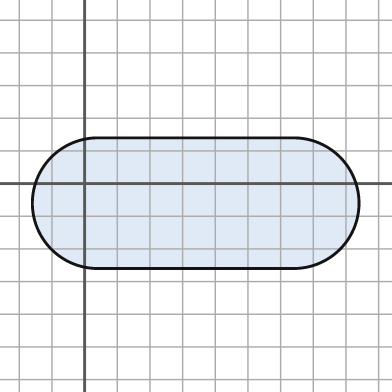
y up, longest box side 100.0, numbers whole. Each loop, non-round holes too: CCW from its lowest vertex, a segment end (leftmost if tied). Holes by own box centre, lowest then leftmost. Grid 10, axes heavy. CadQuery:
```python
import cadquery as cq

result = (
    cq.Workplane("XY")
    .moveTo(4.0, -26.0)
    .lineTo(64.0, -26.0)
    .threePointArc((84.0, -6.0), (64.0, 14.0))
    .lineTo(4.0, 14.0)
    .threePointArc((-16.0, -6.0), (4.0, -26.0))
    .close()
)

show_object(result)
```